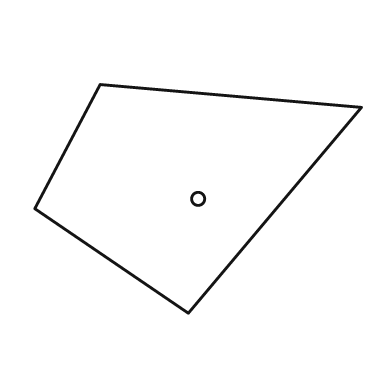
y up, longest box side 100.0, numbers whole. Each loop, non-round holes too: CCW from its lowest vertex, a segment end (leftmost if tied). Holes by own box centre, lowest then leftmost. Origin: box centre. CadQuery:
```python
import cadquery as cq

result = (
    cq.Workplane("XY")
    .moveTo(-3.0, -35.0)
    .lineTo(50.0, 28.0)
    .lineTo(-30.0, 35.0)
    .lineTo(-50.0, -3.0)
    .close()
    .moveTo(0.0, 0.0)
    .circle(2.0)
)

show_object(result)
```